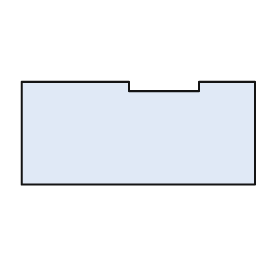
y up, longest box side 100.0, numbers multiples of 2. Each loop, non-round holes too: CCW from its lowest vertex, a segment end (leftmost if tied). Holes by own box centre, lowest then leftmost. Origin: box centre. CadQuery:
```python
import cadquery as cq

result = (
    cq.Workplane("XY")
    .moveTo(-50.0, -22.0)
    .lineTo(50.0, -22.0)
    .lineTo(50.0, 22.0)
    .lineTo(26.0, 22.0)
    .lineTo(26.0, 18.0)
    .lineTo(-4.0, 18.0)
    .lineTo(-4.0, 22.0)
    .lineTo(-50.0, 22.0)
    .close()
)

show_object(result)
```